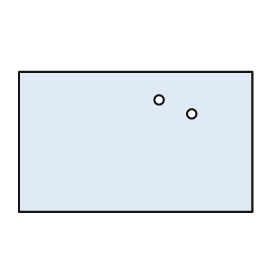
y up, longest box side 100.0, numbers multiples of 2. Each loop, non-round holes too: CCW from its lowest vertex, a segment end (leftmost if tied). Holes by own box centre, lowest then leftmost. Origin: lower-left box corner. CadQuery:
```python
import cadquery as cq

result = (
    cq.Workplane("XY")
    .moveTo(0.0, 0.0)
    .lineTo(100.0, 0.0)
    .lineTo(100.0, 60.0)
    .lineTo(0.0, 60.0)
    .close()
    .moveTo(74.0, 42.0)
    .circle(2.0)
    .moveTo(60.0, 48.0)
    .circle(2.0)
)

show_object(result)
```